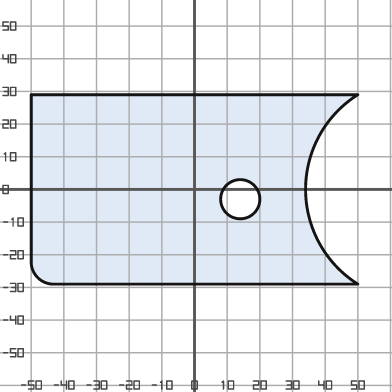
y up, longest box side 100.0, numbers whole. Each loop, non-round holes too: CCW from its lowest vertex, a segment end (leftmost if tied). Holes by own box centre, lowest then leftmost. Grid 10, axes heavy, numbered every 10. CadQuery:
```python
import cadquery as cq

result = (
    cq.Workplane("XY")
    .moveTo(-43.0, -29.0)
    .lineTo(50.0, -29.0)
    .threePointArc((34.0, 0.0), (50.0, 29.0))
    .lineTo(-50.0, 29.0)
    .lineTo(-50.0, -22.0)
    .threePointArc((-48.0, -27.0), (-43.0, -29.0))
    .close()
    .moveTo(14.0, -3.0)
    .circle(6.0)
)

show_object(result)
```